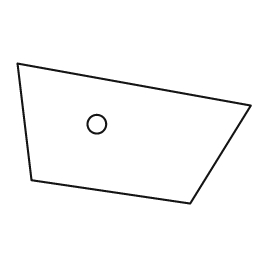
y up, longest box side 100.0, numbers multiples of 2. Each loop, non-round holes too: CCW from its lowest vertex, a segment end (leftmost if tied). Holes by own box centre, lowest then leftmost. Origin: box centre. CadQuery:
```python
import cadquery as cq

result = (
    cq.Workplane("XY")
    .moveTo(24.0, -30.0)
    .lineTo(50.0, 12.0)
    .lineTo(-50.0, 30.0)
    .lineTo(-44.0, -20.0)
    .close()
    .moveTo(-16.0, 4.0)
    .circle(4.0)
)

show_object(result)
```